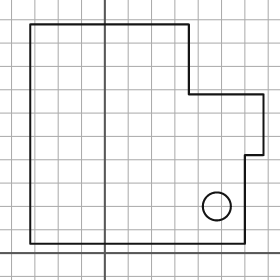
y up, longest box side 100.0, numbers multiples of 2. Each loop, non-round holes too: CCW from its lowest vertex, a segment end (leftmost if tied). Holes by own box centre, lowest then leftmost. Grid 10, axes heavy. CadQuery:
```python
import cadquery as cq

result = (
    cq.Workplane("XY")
    .moveTo(-32.0, 4.0)
    .lineTo(60.0, 4.0)
    .lineTo(60.0, 42.0)
    .lineTo(68.0, 42.0)
    .lineTo(68.0, 68.0)
    .lineTo(36.0, 68.0)
    .lineTo(36.0, 98.0)
    .lineTo(-32.0, 98.0)
    .close()
    .moveTo(48.0, 20.0)
    .circle(6.0)
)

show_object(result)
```